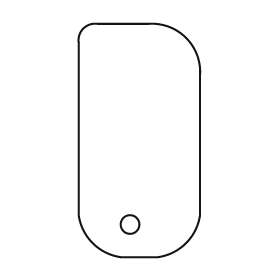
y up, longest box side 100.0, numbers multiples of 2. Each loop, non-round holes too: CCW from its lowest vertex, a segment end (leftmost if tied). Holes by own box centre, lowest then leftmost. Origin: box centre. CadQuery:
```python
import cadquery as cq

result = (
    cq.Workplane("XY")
    .moveTo(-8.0, -50.0)
    .lineTo(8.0, -50.0)
    .threePointArc((20.0, -44.0), (26.0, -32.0))
    .lineTo(26.0, 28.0)
    .threePointArc((20.0, 44.0), (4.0, 50.0))
    .lineTo(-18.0, 50.0)
    .threePointArc((-24.0, 48.0), (-26.0, 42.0))
    .lineTo(-26.0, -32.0)
    .threePointArc((-20.0, -44.0), (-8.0, -50.0))
    .close()
    .moveTo(-4.0, -36.0)
    .circle(4.0)
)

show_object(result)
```